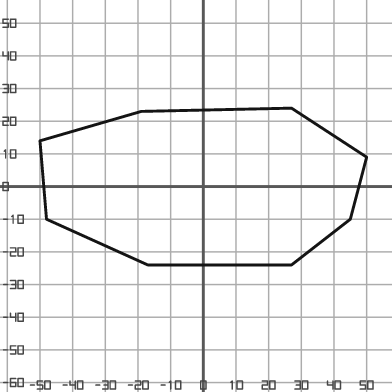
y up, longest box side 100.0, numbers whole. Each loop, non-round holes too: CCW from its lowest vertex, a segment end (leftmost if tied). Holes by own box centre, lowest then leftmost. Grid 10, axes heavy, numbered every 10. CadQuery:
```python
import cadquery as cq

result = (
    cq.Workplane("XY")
    .moveTo(-17.0, -24.0)
    .lineTo(27.0, -24.0)
    .lineTo(45.0, -10.0)
    .lineTo(50.0, 9.0)
    .lineTo(27.0, 24.0)
    .lineTo(-19.0, 23.0)
    .lineTo(-50.0, 14.0)
    .lineTo(-48.0, -10.0)
    .close()
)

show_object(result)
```